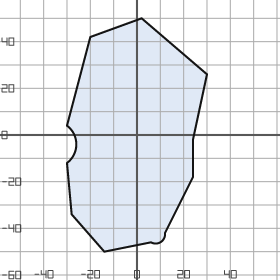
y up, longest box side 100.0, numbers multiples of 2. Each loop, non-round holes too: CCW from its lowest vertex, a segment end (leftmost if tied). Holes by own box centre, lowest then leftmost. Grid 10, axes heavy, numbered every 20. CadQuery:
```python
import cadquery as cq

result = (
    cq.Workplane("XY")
    .moveTo(-14.0, -50.0)
    .lineTo(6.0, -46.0)
    .threePointArc((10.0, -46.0), (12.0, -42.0))
    .lineTo(24.0, -18.0)
    .lineTo(24.0, -2.0)
    .lineTo(30.0, 26.0)
    .lineTo(2.0, 50.0)
    .lineTo(-20.0, 42.0)
    .lineTo(-30.0, 4.0)
    .threePointArc((-26.0, -4.0), (-30.0, -12.0))
    .lineTo(-28.0, -34.0)
    .close()
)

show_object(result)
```